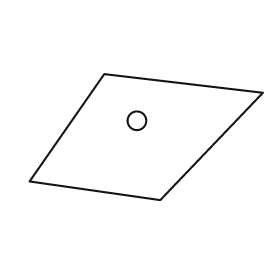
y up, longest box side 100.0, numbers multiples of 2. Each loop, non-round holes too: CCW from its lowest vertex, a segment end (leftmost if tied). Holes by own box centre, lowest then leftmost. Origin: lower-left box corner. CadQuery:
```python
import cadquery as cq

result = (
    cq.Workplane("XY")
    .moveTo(56.0, 0.0)
    .lineTo(100.0, 46.0)
    .lineTo(32.0, 54.0)
    .lineTo(0.0, 8.0)
    .close()
    .moveTo(46.0, 34.0)
    .circle(4.0)
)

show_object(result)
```